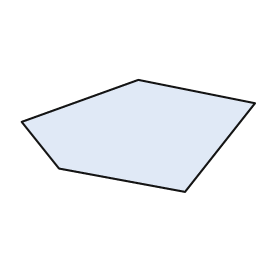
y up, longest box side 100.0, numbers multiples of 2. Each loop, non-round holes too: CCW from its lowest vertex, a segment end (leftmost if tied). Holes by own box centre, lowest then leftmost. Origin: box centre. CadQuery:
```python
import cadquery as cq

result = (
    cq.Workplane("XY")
    .moveTo(20.0, -24.0)
    .lineTo(50.0, 14.0)
    .lineTo(0.0, 24.0)
    .lineTo(-50.0, 6.0)
    .lineTo(-34.0, -14.0)
    .close()
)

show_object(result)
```